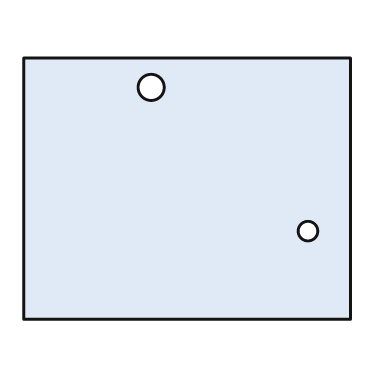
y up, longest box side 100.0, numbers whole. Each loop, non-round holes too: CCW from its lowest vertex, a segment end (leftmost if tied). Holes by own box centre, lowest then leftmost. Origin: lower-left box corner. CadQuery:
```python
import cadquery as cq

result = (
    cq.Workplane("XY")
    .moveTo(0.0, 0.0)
    .lineTo(100.0, 0.0)
    .lineTo(100.0, 80.0)
    .lineTo(0.0, 80.0)
    .close()
    .moveTo(87.0, 27.0)
    .circle(3.0)
    .moveTo(39.0, 71.0)
    .circle(4.0)
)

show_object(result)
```